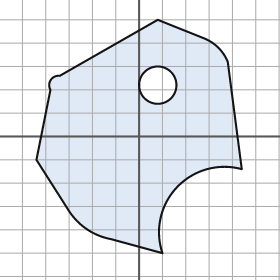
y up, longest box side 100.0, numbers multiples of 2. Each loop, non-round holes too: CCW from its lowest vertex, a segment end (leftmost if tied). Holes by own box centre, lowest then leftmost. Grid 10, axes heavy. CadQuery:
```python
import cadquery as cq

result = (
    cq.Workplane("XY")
    .moveTo(10.0, -50.0)
    .threePointArc((16.0, -22.0), (44.0, -14.0))
    .lineTo(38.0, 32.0)
    .threePointArc((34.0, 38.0), (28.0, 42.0))
    .lineTo(8.0, 50.0)
    .lineTo(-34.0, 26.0)
    .threePointArc((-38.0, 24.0), (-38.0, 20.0))
    .lineTo(-44.0, -10.0)
    .lineTo(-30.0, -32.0)
    .threePointArc((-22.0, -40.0), (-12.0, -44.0))
    .close()
    .moveTo(8.0, 22.0)
    .circle(8.0)
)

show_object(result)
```